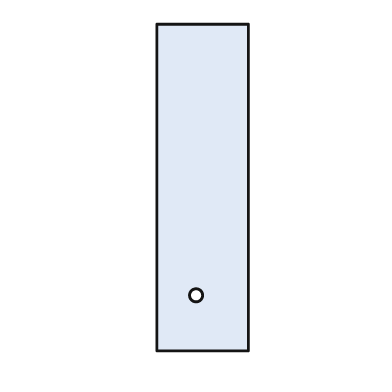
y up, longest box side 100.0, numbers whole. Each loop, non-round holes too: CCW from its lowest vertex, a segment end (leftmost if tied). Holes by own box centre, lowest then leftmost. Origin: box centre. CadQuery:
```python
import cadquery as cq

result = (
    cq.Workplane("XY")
    .moveTo(-14.0, -50.0)
    .lineTo(14.0, -50.0)
    .lineTo(14.0, 50.0)
    .lineTo(-14.0, 50.0)
    .close()
    .moveTo(-2.0, -33.0)
    .circle(2.0)
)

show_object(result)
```